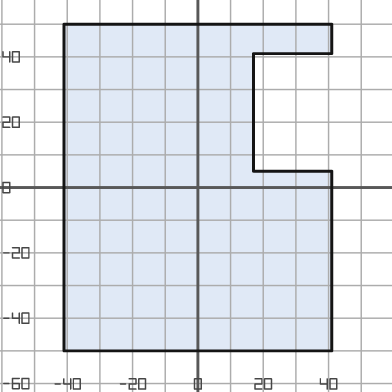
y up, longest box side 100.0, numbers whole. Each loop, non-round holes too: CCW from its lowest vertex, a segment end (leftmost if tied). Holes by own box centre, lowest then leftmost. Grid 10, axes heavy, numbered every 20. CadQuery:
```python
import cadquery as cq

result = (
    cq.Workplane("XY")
    .moveTo(-41.0, -50.0)
    .lineTo(41.0, -50.0)
    .lineTo(41.0, 5.0)
    .lineTo(17.0, 5.0)
    .lineTo(17.0, 41.0)
    .lineTo(41.0, 41.0)
    .lineTo(41.0, 50.0)
    .lineTo(-41.0, 50.0)
    .close()
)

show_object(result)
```